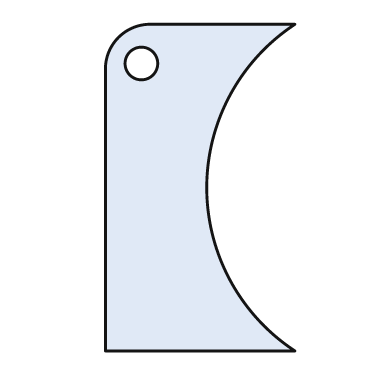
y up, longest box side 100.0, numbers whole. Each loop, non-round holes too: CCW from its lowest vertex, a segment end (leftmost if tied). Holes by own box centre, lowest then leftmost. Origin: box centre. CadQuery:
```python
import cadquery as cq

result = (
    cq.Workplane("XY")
    .moveTo(-29.0, -50.0)
    .lineTo(29.0, -50.0)
    .threePointArc((2.0, 0.0), (29.0, 50.0))
    .lineTo(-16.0, 50.0)
    .threePointArc((-25.0, 46.0), (-29.0, 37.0))
    .close()
    .moveTo(-18.0, 38.0)
    .circle(5.0)
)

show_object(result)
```